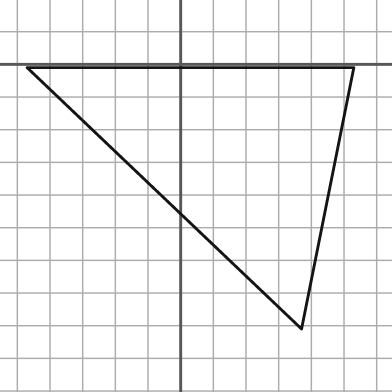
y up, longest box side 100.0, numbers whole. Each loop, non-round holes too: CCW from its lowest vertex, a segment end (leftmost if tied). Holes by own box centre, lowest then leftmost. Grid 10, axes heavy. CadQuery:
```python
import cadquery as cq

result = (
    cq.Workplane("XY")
    .moveTo(37.0, -81.0)
    .lineTo(53.0, -1.0)
    .lineTo(-47.0, -1.0)
    .close()
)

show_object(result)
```